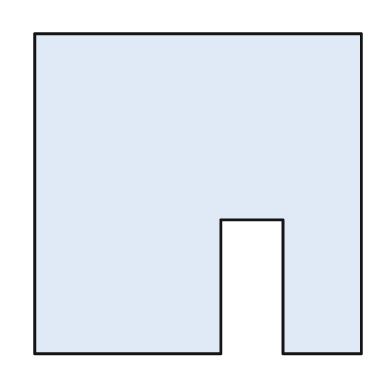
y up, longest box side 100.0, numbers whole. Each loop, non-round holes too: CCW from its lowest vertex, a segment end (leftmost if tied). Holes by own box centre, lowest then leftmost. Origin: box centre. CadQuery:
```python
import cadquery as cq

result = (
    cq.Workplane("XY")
    .moveTo(-50.0, -49.0)
    .lineTo(7.0, -49.0)
    .lineTo(7.0, -8.0)
    .lineTo(26.0, -8.0)
    .lineTo(26.0, -49.0)
    .lineTo(50.0, -49.0)
    .lineTo(50.0, 49.0)
    .lineTo(-50.0, 49.0)
    .close()
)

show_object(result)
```